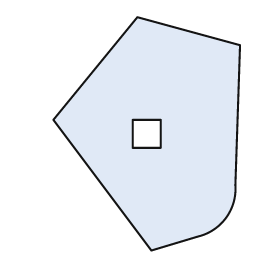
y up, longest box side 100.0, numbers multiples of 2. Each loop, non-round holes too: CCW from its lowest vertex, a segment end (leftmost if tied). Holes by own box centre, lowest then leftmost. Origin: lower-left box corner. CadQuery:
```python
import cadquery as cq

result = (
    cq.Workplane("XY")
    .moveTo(42.0, 0.0)
    .lineTo(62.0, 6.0)
    .threePointArc((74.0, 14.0), (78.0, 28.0))
    .lineTo(80.0, 88.0)
    .lineTo(36.0, 100.0)
    .lineTo(0.0, 56.0)
    .close()
    .moveTo(34.0, 44.0)
    .lineTo(46.0, 44.0)
    .lineTo(46.0, 56.0)
    .lineTo(34.0, 56.0)
    .close()
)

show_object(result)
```